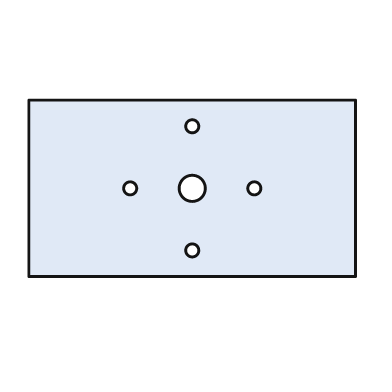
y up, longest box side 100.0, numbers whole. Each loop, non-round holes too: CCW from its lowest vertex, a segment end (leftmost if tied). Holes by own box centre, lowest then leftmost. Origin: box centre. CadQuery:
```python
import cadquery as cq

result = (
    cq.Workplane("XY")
    .moveTo(-50.0, -27.0)
    .lineTo(50.0, -27.0)
    .lineTo(50.0, 27.0)
    .lineTo(-50.0, 27.0)
    .close()
    .moveTo(0.0, -19.0)
    .circle(2.0)
    .moveTo(-19.0, 0.0)
    .circle(2.0)
    .moveTo(0.0, 0.0)
    .circle(4.0)
    .moveTo(19.0, 0.0)
    .circle(2.0)
    .moveTo(0.0, 19.0)
    .circle(2.0)
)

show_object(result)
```